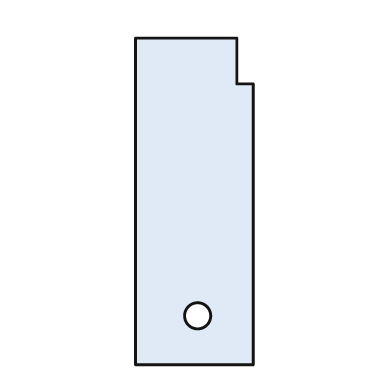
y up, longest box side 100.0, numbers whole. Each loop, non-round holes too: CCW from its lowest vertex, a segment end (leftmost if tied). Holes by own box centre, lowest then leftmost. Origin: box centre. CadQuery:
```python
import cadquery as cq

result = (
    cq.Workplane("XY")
    .moveTo(-18.0, -50.0)
    .lineTo(18.0, -50.0)
    .lineTo(18.0, 36.0)
    .lineTo(13.0, 36.0)
    .lineTo(13.0, 50.0)
    .lineTo(-18.0, 50.0)
    .close()
    .moveTo(1.0, -35.0)
    .circle(4.0)
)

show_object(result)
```